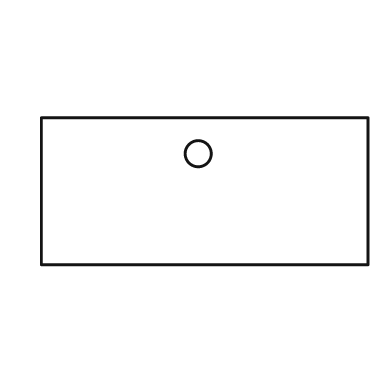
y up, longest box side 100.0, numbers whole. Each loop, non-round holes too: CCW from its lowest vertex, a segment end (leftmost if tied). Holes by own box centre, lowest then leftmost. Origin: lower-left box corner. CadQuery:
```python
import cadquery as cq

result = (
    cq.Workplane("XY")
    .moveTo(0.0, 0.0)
    .lineTo(100.0, 0.0)
    .lineTo(100.0, 45.0)
    .lineTo(0.0, 45.0)
    .close()
    .moveTo(48.0, 34.0)
    .circle(4.0)
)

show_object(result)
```